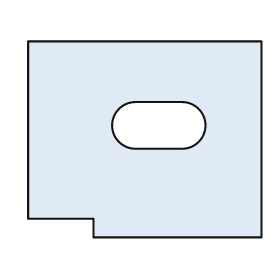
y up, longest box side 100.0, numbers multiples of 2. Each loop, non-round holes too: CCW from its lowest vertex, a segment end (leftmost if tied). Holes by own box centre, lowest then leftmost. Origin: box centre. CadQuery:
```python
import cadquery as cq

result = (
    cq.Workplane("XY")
    .moveTo(-22.0, -42.0)
    .lineTo(50.0, -42.0)
    .lineTo(50.0, 42.0)
    .lineTo(-50.0, 42.0)
    .lineTo(-50.0, -34.0)
    .lineTo(-22.0, -34.0)
    .close()
    .moveTo(-4.0, -4.0)
    .lineTo(16.0, -4.0)
    .threePointArc((26.0, 6.0), (16.0, 16.0))
    .lineTo(-4.0, 16.0)
    .threePointArc((-14.0, 6.0), (-4.0, -4.0))
    .close()
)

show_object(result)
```